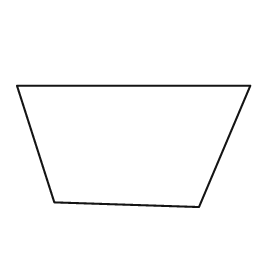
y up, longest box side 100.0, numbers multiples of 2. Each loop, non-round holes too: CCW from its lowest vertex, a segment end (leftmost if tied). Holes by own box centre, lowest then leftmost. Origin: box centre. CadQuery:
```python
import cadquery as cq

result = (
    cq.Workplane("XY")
    .moveTo(28.0, -26.0)
    .lineTo(50.0, 26.0)
    .lineTo(-50.0, 26.0)
    .lineTo(-34.0, -24.0)
    .close()
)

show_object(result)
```